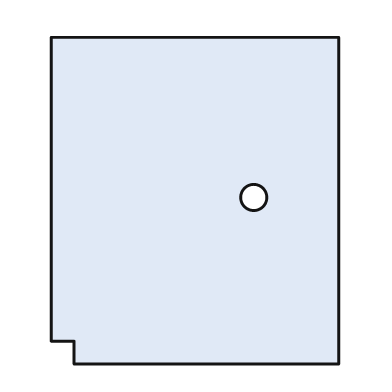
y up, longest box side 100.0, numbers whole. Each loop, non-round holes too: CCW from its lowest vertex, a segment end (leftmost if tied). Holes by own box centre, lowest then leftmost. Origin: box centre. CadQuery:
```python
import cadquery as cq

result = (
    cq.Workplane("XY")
    .moveTo(-37.0, -50.0)
    .lineTo(44.0, -50.0)
    .lineTo(44.0, 50.0)
    .lineTo(-44.0, 50.0)
    .lineTo(-44.0, -43.0)
    .lineTo(-37.0, -43.0)
    .close()
    .moveTo(18.0, 1.0)
    .circle(4.0)
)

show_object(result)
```